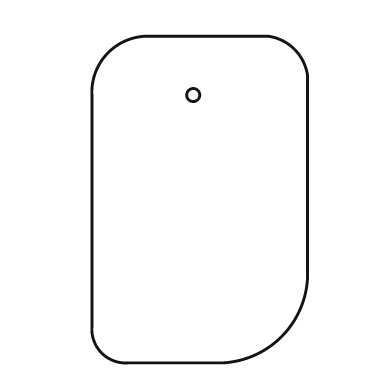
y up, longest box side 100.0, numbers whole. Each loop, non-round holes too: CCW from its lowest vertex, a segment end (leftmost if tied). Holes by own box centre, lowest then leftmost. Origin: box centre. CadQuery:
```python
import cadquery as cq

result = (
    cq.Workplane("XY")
    .moveTo(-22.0, -50.0)
    .lineTo(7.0, -50.0)
    .threePointArc((25.0, -42.0), (33.0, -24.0))
    .lineTo(33.0, 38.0)
    .threePointArc((29.0, 46.0), (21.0, 50.0))
    .lineTo(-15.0, 50.0)
    .threePointArc((-28.0, 45.0), (-33.0, 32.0))
    .lineTo(-33.0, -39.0)
    .threePointArc((-30.0, -47.0), (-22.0, -50.0))
    .close()
    .moveTo(-2.0, 32.0)
    .circle(2.0)
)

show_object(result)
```